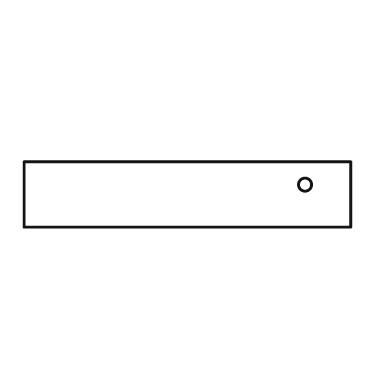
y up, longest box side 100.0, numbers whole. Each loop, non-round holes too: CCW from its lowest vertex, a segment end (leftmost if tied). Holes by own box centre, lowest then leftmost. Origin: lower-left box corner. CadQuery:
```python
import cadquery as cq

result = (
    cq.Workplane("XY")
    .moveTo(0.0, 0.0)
    .lineTo(100.0, 0.0)
    .lineTo(100.0, 20.0)
    .lineTo(0.0, 20.0)
    .close()
    .moveTo(86.0, 13.0)
    .circle(2.0)
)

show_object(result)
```